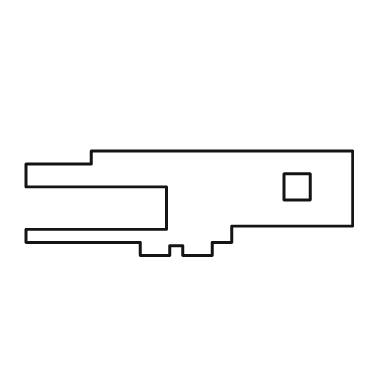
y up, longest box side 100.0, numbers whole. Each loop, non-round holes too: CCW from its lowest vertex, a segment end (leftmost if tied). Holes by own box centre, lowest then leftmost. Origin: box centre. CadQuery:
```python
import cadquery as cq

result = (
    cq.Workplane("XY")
    .moveTo(-15.0, -16.0)
    .lineTo(-6.0, -16.0)
    .lineTo(-6.0, -13.0)
    .lineTo(-2.0, -13.0)
    .lineTo(-2.0, -16.0)
    .lineTo(7.0, -16.0)
    .lineTo(7.0, -12.0)
    .lineTo(13.0, -12.0)
    .lineTo(13.0, -7.0)
    .lineTo(50.0, -7.0)
    .lineTo(50.0, 16.0)
    .lineTo(-30.0, 16.0)
    .lineTo(-30.0, 12.0)
    .lineTo(-50.0, 12.0)
    .lineTo(-50.0, 5.0)
    .lineTo(-7.0, 5.0)
    .lineTo(-7.0, -8.0)
    .lineTo(-50.0, -8.0)
    .lineTo(-50.0, -12.0)
    .lineTo(-15.0, -12.0)
    .close()
    .moveTo(29.0, 1.0)
    .lineTo(37.0, 1.0)
    .lineTo(37.0, 9.0)
    .lineTo(29.0, 9.0)
    .close()
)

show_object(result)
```